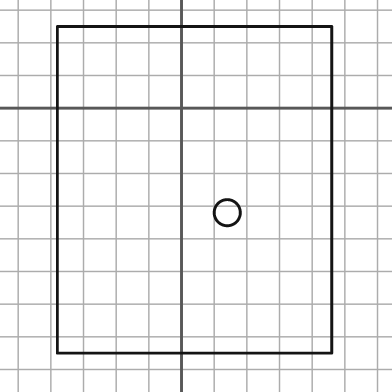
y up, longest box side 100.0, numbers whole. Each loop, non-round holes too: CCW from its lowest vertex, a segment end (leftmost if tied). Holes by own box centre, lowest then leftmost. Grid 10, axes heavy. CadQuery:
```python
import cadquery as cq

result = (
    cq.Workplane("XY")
    .moveTo(-38.0, -75.0)
    .lineTo(46.0, -75.0)
    .lineTo(46.0, 25.0)
    .lineTo(-38.0, 25.0)
    .close()
    .moveTo(14.0, -32.0)
    .circle(4.0)
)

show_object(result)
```